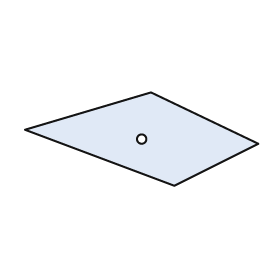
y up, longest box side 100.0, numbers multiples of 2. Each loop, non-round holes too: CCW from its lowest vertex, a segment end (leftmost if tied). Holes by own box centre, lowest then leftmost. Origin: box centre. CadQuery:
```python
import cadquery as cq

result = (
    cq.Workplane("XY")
    .moveTo(14.0, -20.0)
    .lineTo(50.0, -2.0)
    .lineTo(4.0, 20.0)
    .lineTo(-50.0, 4.0)
    .close()
    .moveTo(0.0, 0.0)
    .circle(2.0)
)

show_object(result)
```